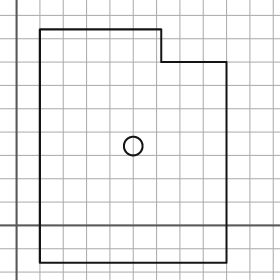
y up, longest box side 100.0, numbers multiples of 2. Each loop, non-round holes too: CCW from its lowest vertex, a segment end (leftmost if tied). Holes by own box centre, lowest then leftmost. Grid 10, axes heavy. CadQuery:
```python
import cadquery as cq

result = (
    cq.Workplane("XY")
    .moveTo(10.0, -16.0)
    .lineTo(90.0, -16.0)
    .lineTo(90.0, 70.0)
    .lineTo(62.0, 70.0)
    .lineTo(62.0, 84.0)
    .lineTo(10.0, 84.0)
    .close()
    .moveTo(50.0, 34.0)
    .circle(4.0)
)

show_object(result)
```